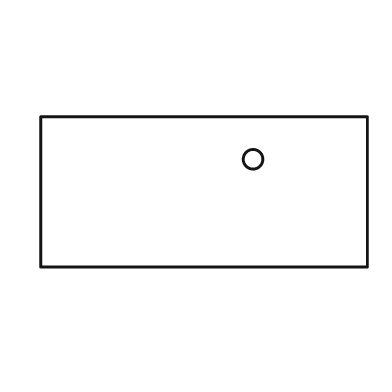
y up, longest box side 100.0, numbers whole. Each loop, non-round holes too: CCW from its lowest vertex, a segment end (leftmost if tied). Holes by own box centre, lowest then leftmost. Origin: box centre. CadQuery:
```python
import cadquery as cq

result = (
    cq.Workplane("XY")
    .moveTo(-50.0, -23.0)
    .lineTo(50.0, -23.0)
    .lineTo(50.0, 23.0)
    .lineTo(-50.0, 23.0)
    .close()
    .moveTo(15.0, 10.0)
    .circle(3.0)
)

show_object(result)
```